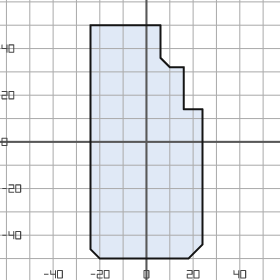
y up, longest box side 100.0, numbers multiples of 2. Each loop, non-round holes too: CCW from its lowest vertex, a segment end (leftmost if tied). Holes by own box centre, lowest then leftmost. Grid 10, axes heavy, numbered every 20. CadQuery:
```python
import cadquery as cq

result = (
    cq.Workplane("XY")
    .moveTo(-20.0, -50.0)
    .lineTo(18.0, -50.0)
    .lineTo(24.0, -44.0)
    .lineTo(24.0, 14.0)
    .lineTo(16.0, 14.0)
    .lineTo(16.0, 32.0)
    .lineTo(10.0, 32.0)
    .lineTo(6.0, 36.0)
    .lineTo(6.0, 50.0)
    .lineTo(-24.0, 50.0)
    .lineTo(-24.0, -46.0)
    .close()
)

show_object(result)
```